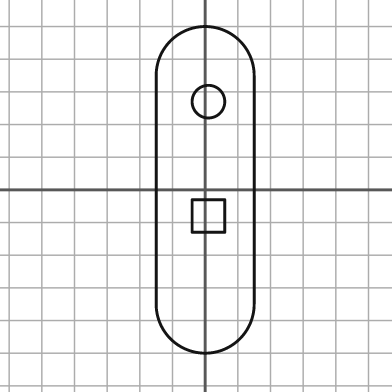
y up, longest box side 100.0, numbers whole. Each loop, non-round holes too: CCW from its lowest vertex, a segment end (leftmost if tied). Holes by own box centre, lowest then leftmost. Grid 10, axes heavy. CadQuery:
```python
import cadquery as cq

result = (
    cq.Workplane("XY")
    .moveTo(-15.0, -35.0)
    .threePointArc((0.0, -50.0), (15.0, -35.0))
    .lineTo(15.0, 35.0)
    .threePointArc((0.0, 50.0), (-15.0, 35.0))
    .close()
    .moveTo(-4.0, -13.0)
    .lineTo(6.0, -13.0)
    .lineTo(6.0, -3.0)
    .lineTo(-4.0, -3.0)
    .close()
    .moveTo(1.0, 27.0)
    .circle(5.0)
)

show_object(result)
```